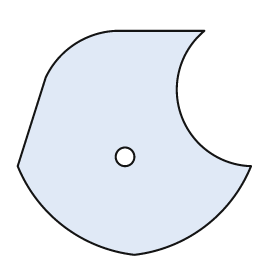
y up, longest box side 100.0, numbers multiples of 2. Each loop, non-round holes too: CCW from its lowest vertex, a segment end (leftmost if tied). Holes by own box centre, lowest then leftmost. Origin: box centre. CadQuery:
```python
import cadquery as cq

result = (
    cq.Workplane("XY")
    .moveTo(0.0, -48.0)
    .threePointArc((30.0, -36.0), (50.0, -10.0))
    .threePointArc((20.0, 12.0), (30.0, 48.0))
    .lineTo(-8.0, 48.0)
    .threePointArc((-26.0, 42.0), (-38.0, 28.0))
    .lineTo(-50.0, -10.0)
    .threePointArc((-30.0, -36.0), (0.0, -48.0))
    .close()
    .moveTo(-4.0, -6.0)
    .circle(4.0)
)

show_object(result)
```